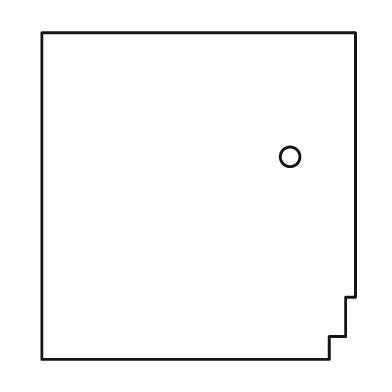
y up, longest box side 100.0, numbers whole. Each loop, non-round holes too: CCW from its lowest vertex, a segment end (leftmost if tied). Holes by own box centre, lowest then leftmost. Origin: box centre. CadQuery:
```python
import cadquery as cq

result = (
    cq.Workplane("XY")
    .moveTo(-48.0, -50.0)
    .lineTo(40.0, -50.0)
    .lineTo(40.0, -43.0)
    .lineTo(45.0, -43.0)
    .lineTo(45.0, -31.0)
    .lineTo(48.0, -31.0)
    .lineTo(48.0, 50.0)
    .lineTo(-48.0, 50.0)
    .close()
    .moveTo(28.0, 12.0)
    .circle(3.0)
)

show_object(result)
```